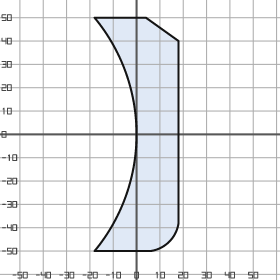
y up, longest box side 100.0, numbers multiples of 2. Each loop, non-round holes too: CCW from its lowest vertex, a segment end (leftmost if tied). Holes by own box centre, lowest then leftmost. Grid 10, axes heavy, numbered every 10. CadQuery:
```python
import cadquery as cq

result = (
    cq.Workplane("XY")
    .moveTo(-18.0, -50.0)
    .lineTo(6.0, -50.0)
    .threePointArc((14.0, -46.0), (18.0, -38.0))
    .lineTo(18.0, 40.0)
    .lineTo(4.0, 50.0)
    .lineTo(-18.0, 50.0)
    .threePointArc((0.0, 0.0), (-18.0, -50.0))
    .close()
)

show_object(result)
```